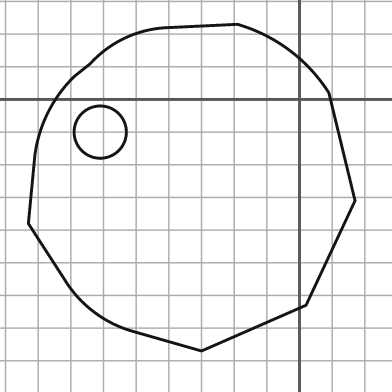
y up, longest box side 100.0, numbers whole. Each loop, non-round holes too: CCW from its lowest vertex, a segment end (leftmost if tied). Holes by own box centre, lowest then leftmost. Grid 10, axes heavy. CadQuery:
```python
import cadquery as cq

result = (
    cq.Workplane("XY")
    .moveTo(-30.0, -77.0)
    .lineTo(2.0, -63.0)
    .lineTo(17.0, -31.0)
    .lineTo(9.0, 2.0)
    .threePointArc((-3.0, 15.0), (-19.0, 23.0))
    .lineTo(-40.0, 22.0)
    .threePointArc((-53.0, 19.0), (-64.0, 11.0))
    .lineTo(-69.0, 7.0)
    .threePointArc((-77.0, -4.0), (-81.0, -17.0))
    .lineTo(-83.0, -38.0)
    .lineTo(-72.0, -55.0)
    .threePointArc((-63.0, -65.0), (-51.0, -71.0))
    .close()
    .moveTo(-61.0, -10.0)
    .circle(8.0)
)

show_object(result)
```